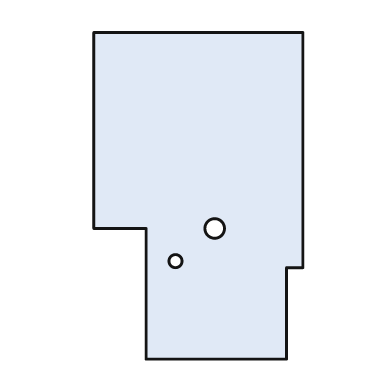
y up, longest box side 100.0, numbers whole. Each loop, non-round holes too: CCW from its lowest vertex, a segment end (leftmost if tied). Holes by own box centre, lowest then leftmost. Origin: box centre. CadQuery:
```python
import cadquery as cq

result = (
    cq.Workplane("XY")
    .moveTo(-16.0, -50.0)
    .lineTo(27.0, -50.0)
    .lineTo(27.0, -22.0)
    .lineTo(32.0, -22.0)
    .lineTo(32.0, 50.0)
    .lineTo(-32.0, 50.0)
    .lineTo(-32.0, -10.0)
    .lineTo(-16.0, -10.0)
    .close()
    .moveTo(-7.0, -20.0)
    .circle(2.0)
    .moveTo(5.0, -10.0)
    .circle(3.0)
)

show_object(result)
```